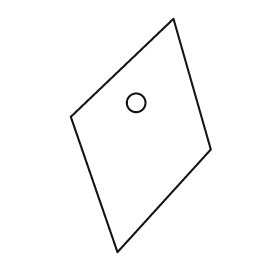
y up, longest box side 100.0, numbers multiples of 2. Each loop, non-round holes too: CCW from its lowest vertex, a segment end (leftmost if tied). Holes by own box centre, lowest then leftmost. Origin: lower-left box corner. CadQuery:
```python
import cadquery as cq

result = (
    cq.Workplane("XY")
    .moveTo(20.0, 0.0)
    .lineTo(60.0, 44.0)
    .lineTo(44.0, 100.0)
    .lineTo(0.0, 58.0)
    .close()
    .moveTo(28.0, 64.0)
    .circle(4.0)
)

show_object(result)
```